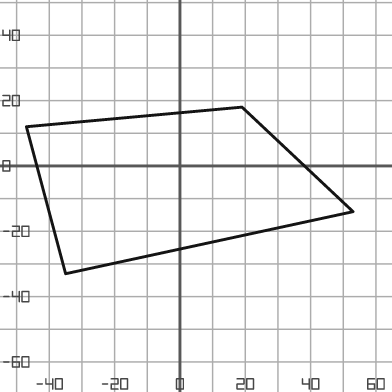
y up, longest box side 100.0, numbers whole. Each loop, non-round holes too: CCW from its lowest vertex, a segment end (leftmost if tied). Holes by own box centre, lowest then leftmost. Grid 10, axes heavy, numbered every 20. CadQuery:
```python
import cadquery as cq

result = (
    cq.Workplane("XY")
    .moveTo(-35.0, -33.0)
    .lineTo(53.0, -14.0)
    .lineTo(19.0, 18.0)
    .lineTo(-47.0, 12.0)
    .close()
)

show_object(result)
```